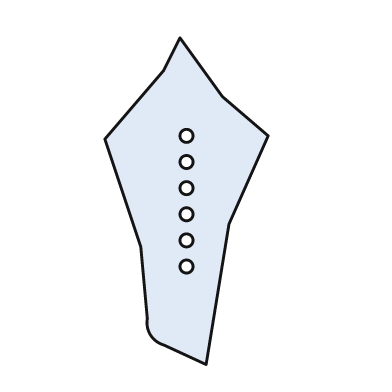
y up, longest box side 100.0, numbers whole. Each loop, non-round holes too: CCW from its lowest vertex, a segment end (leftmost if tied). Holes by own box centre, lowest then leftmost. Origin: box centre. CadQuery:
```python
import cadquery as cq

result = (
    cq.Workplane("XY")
    .moveTo(6.0, -50.0)
    .lineTo(13.0, -7.0)
    .lineTo(25.0, 20.0)
    .lineTo(11.0, 32.0)
    .lineTo(-2.0, 50.0)
    .lineTo(-7.0, 40.0)
    .lineTo(-25.0, 19.0)
    .lineTo(-14.0, -14.0)
    .lineTo(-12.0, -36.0)
    .threePointArc((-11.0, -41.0), (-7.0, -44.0))
    .close()
    .moveTo(0.0, -20.0)
    .circle(2.0)
    .moveTo(0.0, -12.0)
    .circle(2.0)
    .moveTo(0.0, -4.0)
    .circle(2.0)
    .moveTo(0.0, 4.0)
    .circle(2.0)
    .moveTo(0.0, 12.0)
    .circle(2.0)
    .moveTo(0.0, 20.0)
    .circle(2.0)
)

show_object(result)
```